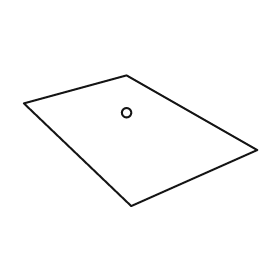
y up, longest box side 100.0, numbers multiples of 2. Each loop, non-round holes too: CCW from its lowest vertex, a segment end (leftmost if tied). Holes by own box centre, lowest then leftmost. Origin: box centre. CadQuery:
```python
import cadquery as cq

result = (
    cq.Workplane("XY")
    .moveTo(-4.0, -28.0)
    .lineTo(50.0, -4.0)
    .lineTo(-6.0, 28.0)
    .lineTo(-50.0, 16.0)
    .close()
    .moveTo(-6.0, 12.0)
    .circle(2.0)
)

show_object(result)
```